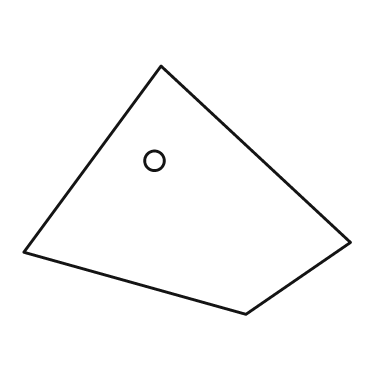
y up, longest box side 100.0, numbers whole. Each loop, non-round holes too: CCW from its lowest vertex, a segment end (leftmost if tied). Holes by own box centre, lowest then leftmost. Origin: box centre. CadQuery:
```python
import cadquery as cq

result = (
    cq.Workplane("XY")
    .moveTo(18.0, -38.0)
    .lineTo(50.0, -16.0)
    .lineTo(-8.0, 38.0)
    .lineTo(-50.0, -19.0)
    .close()
    .moveTo(-10.0, 9.0)
    .circle(3.0)
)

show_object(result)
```